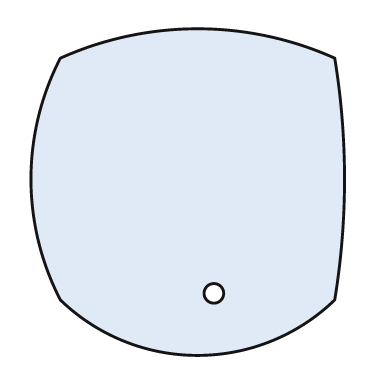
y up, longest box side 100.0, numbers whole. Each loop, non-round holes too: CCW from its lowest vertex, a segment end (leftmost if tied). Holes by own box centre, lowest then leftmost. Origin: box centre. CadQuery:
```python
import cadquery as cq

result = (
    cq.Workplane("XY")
    .moveTo(-39.0, -33.0)
    .threePointArc((3.0, -50.0), (45.0, -33.0))
    .threePointArc((48.0, 4.0), (45.0, 41.0))
    .threePointArc((3.0, 50.0), (-39.0, 41.0))
    .threePointArc((-48.0, 4.0), (-39.0, -33.0))
    .close()
    .moveTo(8.0, -31.0)
    .circle(3.0)
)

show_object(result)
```